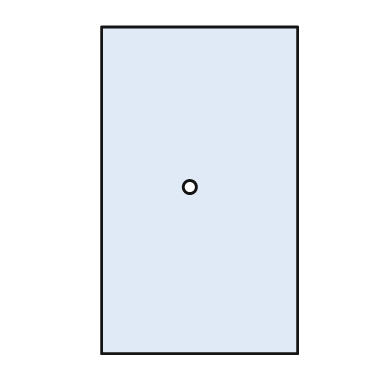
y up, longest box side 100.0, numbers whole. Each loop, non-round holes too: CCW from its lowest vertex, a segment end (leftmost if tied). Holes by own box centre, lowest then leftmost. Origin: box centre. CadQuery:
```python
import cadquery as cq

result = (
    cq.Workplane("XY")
    .moveTo(-30.0, -50.0)
    .lineTo(30.0, -50.0)
    .lineTo(30.0, 50.0)
    .lineTo(-30.0, 50.0)
    .close()
    .moveTo(-3.0, 1.0)
    .circle(2.0)
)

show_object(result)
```